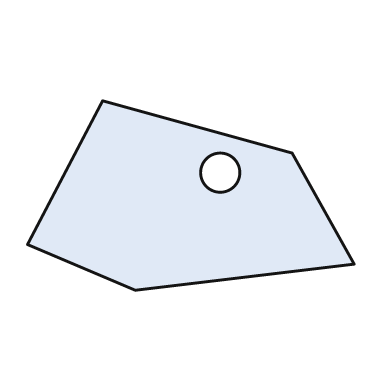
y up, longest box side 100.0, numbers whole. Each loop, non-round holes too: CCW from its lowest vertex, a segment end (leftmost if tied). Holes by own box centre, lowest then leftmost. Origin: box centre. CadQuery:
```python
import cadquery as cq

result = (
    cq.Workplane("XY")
    .moveTo(-17.0, -29.0)
    .lineTo(50.0, -21.0)
    .lineTo(31.0, 13.0)
    .lineTo(-27.0, 29.0)
    .lineTo(-50.0, -15.0)
    .close()
    .moveTo(9.0, 7.0)
    .circle(6.0)
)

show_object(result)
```